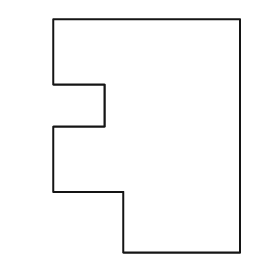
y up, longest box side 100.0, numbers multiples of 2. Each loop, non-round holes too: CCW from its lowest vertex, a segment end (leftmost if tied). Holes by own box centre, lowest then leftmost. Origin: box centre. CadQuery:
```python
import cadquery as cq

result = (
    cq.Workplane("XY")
    .moveTo(-10.0, -50.0)
    .lineTo(40.0, -50.0)
    .lineTo(40.0, 50.0)
    .lineTo(-40.0, 50.0)
    .lineTo(-40.0, 22.0)
    .lineTo(-18.0, 22.0)
    .lineTo(-18.0, 4.0)
    .lineTo(-40.0, 4.0)
    .lineTo(-40.0, -24.0)
    .lineTo(-10.0, -24.0)
    .close()
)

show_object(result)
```